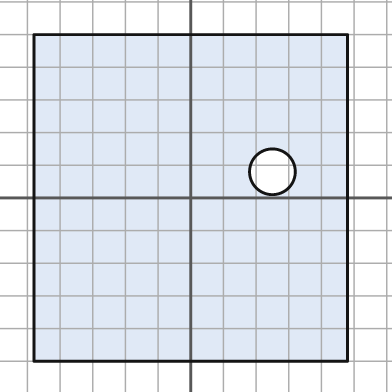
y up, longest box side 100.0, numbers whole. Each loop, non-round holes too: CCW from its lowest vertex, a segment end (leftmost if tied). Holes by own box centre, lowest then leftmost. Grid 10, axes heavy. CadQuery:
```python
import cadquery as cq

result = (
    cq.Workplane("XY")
    .moveTo(-48.0, -50.0)
    .lineTo(48.0, -50.0)
    .lineTo(48.0, 50.0)
    .lineTo(-48.0, 50.0)
    .close()
    .moveTo(25.0, 8.0)
    .circle(7.0)
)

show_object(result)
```